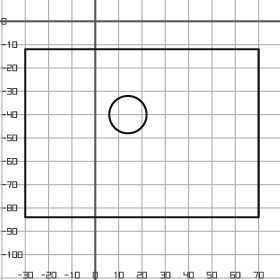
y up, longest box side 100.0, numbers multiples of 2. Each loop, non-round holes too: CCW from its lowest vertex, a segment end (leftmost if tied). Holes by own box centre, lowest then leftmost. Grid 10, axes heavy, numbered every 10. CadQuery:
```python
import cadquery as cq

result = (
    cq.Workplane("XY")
    .moveTo(-30.0, -84.0)
    .lineTo(70.0, -84.0)
    .lineTo(70.0, -12.0)
    .lineTo(-30.0, -12.0)
    .close()
    .moveTo(14.0, -40.0)
    .circle(8.0)
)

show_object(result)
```